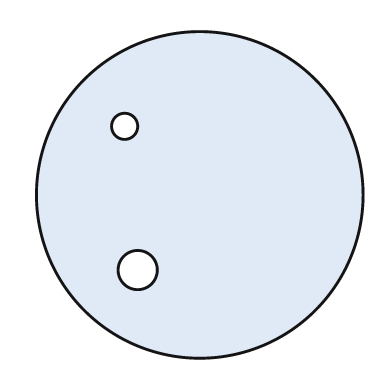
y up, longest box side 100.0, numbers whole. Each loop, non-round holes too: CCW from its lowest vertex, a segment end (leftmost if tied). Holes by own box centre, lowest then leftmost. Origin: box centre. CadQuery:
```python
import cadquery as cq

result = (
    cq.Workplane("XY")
    .moveTo(0.0, 0.0)
    .circle(50.0)
    .moveTo(-19.0, -23.0)
    .circle(6.0)
    .moveTo(-23.0, 21.0)
    .circle(4.0)
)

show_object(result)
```